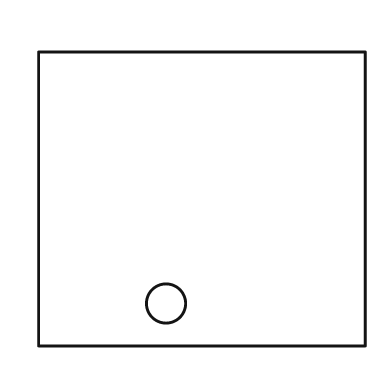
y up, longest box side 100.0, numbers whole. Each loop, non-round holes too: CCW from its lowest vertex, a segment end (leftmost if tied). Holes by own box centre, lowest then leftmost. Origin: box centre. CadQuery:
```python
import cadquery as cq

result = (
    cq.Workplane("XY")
    .moveTo(-50.0, -45.0)
    .lineTo(50.0, -45.0)
    .lineTo(50.0, 45.0)
    .lineTo(-50.0, 45.0)
    .close()
    .moveTo(-11.0, -32.0)
    .circle(6.0)
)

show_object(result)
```